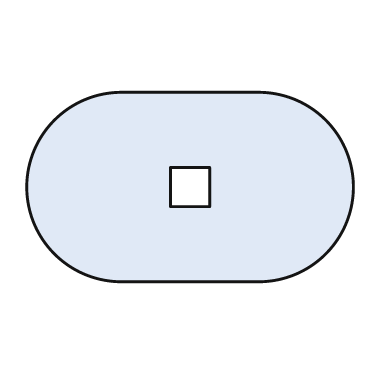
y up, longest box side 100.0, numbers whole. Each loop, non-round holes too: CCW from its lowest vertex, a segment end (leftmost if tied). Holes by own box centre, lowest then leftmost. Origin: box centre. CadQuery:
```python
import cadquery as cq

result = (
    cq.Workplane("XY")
    .moveTo(-21.0, -29.0)
    .lineTo(21.0, -29.0)
    .threePointArc((50.0, 0.0), (21.0, 29.0))
    .lineTo(-21.0, 29.0)
    .threePointArc((-50.0, 0.0), (-21.0, -29.0))
    .close()
    .moveTo(-6.0, -6.0)
    .lineTo(6.0, -6.0)
    .lineTo(6.0, 6.0)
    .lineTo(-6.0, 6.0)
    .close()
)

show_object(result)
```